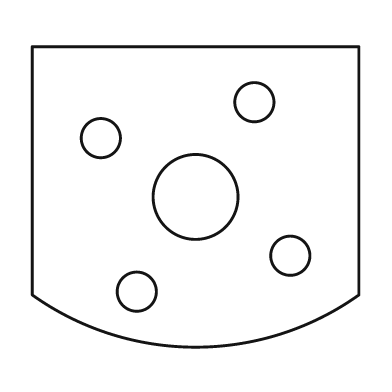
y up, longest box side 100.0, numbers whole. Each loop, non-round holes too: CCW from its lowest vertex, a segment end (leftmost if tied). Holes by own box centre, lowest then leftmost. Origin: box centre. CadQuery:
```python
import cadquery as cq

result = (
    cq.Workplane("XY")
    .moveTo(-50.0, -30.0)
    .threePointArc((0.0, -46.0), (50.0, -30.0))
    .lineTo(50.0, 46.0)
    .lineTo(-50.0, 46.0)
    .close()
    .moveTo(-18.0, -29.0)
    .circle(6.0)
    .moveTo(29.0, -18.0)
    .circle(6.0)
    .moveTo(0.0, 0.0)
    .circle(13.0)
    .moveTo(-29.0, 18.0)
    .circle(6.0)
    .moveTo(18.0, 29.0)
    .circle(6.0)
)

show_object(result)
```